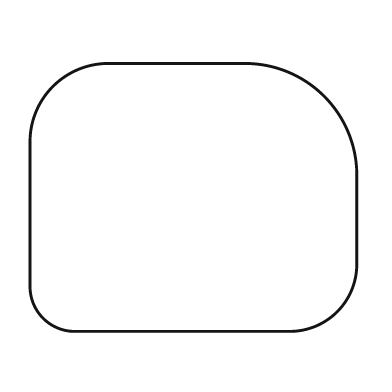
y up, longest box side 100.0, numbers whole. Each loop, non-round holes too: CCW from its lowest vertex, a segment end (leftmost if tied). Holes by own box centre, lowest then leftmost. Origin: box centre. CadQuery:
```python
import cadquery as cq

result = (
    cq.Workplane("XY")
    .moveTo(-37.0, -41.0)
    .lineTo(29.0, -41.0)
    .threePointArc((44.0, -35.0), (50.0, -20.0))
    .lineTo(50.0, 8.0)
    .threePointArc((40.0, 31.0), (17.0, 41.0))
    .lineTo(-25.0, 41.0)
    .threePointArc((-43.0, 34.0), (-50.0, 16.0))
    .lineTo(-50.0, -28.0)
    .threePointArc((-46.0, -37.0), (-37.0, -41.0))
    .close()
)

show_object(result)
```